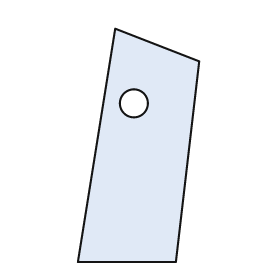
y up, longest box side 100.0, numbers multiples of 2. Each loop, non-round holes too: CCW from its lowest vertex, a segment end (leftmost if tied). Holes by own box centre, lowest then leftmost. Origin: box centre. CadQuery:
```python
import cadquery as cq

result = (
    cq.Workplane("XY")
    .moveTo(-26.0, -50.0)
    .lineTo(16.0, -50.0)
    .lineTo(26.0, 36.0)
    .lineTo(-10.0, 50.0)
    .close()
    .moveTo(-2.0, 18.0)
    .circle(6.0)
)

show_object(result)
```